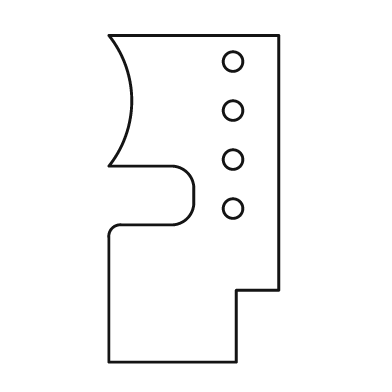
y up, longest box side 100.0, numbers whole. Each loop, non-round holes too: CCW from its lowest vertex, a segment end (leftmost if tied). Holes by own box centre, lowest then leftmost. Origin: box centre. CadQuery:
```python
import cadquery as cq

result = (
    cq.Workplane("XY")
    .moveTo(-26.0, -50.0)
    .lineTo(13.0, -50.0)
    .lineTo(13.0, -28.0)
    .lineTo(26.0, -28.0)
    .lineTo(26.0, 50.0)
    .lineTo(-26.0, 50.0)
    .threePointArc((-19.0, 30.0), (-26.0, 10.0))
    .lineTo(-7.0, 10.0)
    .threePointArc((-2.0, 8.0), (0.0, 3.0))
    .lineTo(0.0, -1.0)
    .threePointArc((-2.0, -6.0), (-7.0, -8.0))
    .lineTo(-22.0, -8.0)
    .threePointArc((-25.0, -9.0), (-26.0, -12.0))
    .close()
    .moveTo(12.0, -3.0)
    .circle(3.0)
    .moveTo(12.0, 12.0)
    .circle(3.0)
    .moveTo(12.0, 27.0)
    .circle(3.0)
    .moveTo(12.0, 42.0)
    .circle(3.0)
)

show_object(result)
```